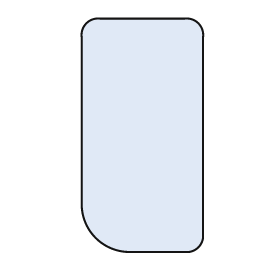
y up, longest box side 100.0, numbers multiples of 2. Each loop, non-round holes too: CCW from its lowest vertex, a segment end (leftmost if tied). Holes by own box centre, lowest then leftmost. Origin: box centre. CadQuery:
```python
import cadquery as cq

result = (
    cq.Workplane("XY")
    .moveTo(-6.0, -50.0)
    .lineTo(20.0, -50.0)
    .threePointArc((24.0, -48.0), (26.0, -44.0))
    .lineTo(26.0, 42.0)
    .threePointArc((24.0, 48.0), (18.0, 50.0))
    .lineTo(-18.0, 50.0)
    .threePointArc((-24.0, 48.0), (-26.0, 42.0))
    .lineTo(-26.0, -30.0)
    .threePointArc((-20.0, -44.0), (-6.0, -50.0))
    .close()
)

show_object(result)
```